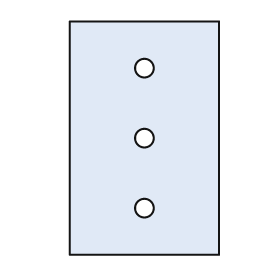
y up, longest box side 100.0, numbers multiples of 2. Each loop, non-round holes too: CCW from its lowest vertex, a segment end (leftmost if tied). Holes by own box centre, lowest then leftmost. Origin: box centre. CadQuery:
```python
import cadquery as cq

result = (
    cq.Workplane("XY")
    .moveTo(-32.0, -50.0)
    .lineTo(32.0, -50.0)
    .lineTo(32.0, 50.0)
    .lineTo(-32.0, 50.0)
    .close()
    .moveTo(0.0, -30.0)
    .circle(4.0)
    .moveTo(0.0, 0.0)
    .circle(4.0)
    .moveTo(0.0, 30.0)
    .circle(4.0)
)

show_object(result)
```